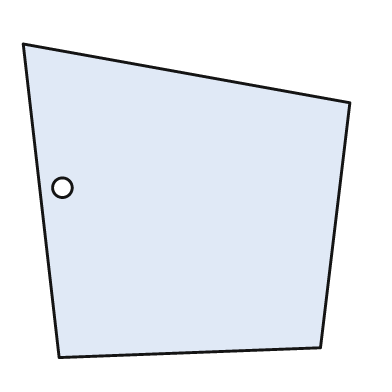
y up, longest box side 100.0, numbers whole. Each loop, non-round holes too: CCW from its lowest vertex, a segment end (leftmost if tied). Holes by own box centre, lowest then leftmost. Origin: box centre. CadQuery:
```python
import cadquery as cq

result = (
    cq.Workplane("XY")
    .moveTo(-39.0, -48.0)
    .lineTo(41.0, -45.0)
    .lineTo(50.0, 30.0)
    .lineTo(-50.0, 48.0)
    .close()
    .moveTo(-38.0, 4.0)
    .circle(3.0)
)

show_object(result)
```